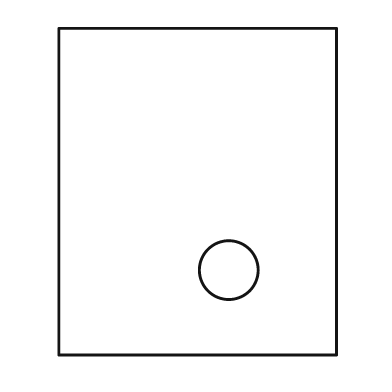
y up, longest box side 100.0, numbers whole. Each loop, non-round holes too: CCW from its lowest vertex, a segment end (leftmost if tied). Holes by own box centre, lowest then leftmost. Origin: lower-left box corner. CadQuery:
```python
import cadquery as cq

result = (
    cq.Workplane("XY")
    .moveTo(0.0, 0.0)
    .lineTo(85.0, 0.0)
    .lineTo(85.0, 100.0)
    .lineTo(0.0, 100.0)
    .close()
    .moveTo(52.0, 26.0)
    .circle(9.0)
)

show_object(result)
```